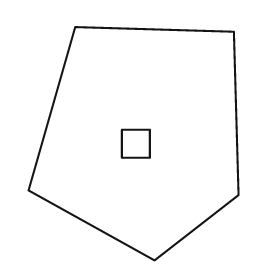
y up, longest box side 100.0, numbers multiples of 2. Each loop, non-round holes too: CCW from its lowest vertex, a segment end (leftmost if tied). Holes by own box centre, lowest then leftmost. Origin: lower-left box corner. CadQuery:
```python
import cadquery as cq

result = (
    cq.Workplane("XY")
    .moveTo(54.0, 0.0)
    .lineTo(90.0, 28.0)
    .lineTo(88.0, 98.0)
    .lineTo(20.0, 100.0)
    .lineTo(0.0, 30.0)
    .close()
    .moveTo(40.0, 44.0)
    .lineTo(52.0, 44.0)
    .lineTo(52.0, 56.0)
    .lineTo(40.0, 56.0)
    .close()
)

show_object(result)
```